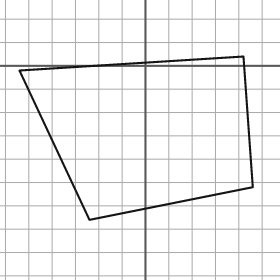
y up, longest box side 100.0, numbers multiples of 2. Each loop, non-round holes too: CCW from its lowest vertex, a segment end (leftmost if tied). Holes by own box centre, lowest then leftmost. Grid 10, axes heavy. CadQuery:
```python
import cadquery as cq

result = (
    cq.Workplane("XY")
    .moveTo(-24.0, -66.0)
    .lineTo(46.0, -52.0)
    .lineTo(42.0, 4.0)
    .lineTo(-54.0, -2.0)
    .close()
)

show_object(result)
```